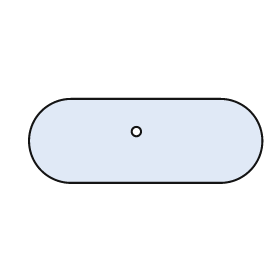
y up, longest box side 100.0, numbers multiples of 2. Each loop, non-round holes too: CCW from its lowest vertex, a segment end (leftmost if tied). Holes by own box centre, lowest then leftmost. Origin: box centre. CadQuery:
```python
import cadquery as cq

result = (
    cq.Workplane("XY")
    .moveTo(-32.0, -18.0)
    .lineTo(32.0, -18.0)
    .threePointArc((50.0, 0.0), (32.0, 18.0))
    .lineTo(-32.0, 18.0)
    .threePointArc((-50.0, 0.0), (-32.0, -18.0))
    .close()
    .moveTo(-4.0, 4.0)
    .circle(2.0)
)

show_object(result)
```